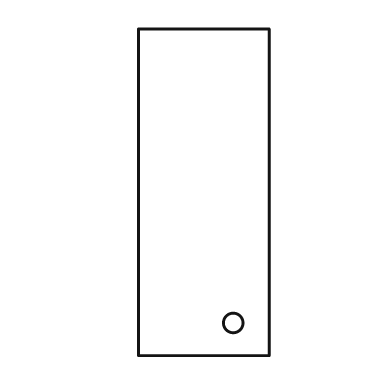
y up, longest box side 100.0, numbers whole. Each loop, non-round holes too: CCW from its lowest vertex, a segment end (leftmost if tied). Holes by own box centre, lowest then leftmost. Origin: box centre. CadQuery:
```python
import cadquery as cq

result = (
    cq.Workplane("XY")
    .moveTo(-20.0, -50.0)
    .lineTo(20.0, -50.0)
    .lineTo(20.0, 50.0)
    .lineTo(-20.0, 50.0)
    .close()
    .moveTo(9.0, -40.0)
    .circle(3.0)
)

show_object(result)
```